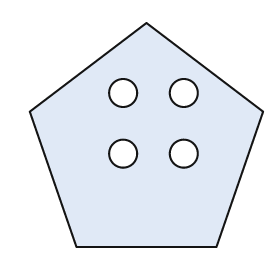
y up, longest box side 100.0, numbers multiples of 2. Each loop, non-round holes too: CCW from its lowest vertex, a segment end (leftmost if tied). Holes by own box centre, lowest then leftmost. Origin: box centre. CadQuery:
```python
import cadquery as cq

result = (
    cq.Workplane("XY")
    .moveTo(-30.0, -48.0)
    .lineTo(30.0, -48.0)
    .lineTo(50.0, 10.0)
    .lineTo(0.0, 48.0)
    .lineTo(-50.0, 10.0)
    .close()
    .moveTo(-10.0, -8.0)
    .circle(6.0)
    .moveTo(16.0, -8.0)
    .circle(6.0)
    .moveTo(-10.0, 18.0)
    .circle(6.0)
    .moveTo(16.0, 18.0)
    .circle(6.0)
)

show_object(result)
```